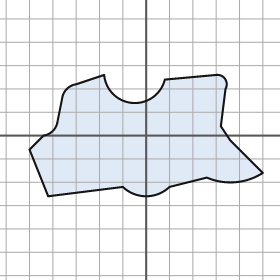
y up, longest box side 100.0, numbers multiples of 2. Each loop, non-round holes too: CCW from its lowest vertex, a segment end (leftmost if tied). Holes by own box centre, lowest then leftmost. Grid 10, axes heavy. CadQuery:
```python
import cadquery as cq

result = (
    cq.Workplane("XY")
    .moveTo(-42.0, -26.0)
    .lineTo(-10.0, -22.0)
    .threePointArc((0.0, -26.0), (10.0, -22.0))
    .lineTo(26.0, -18.0)
    .threePointArc((38.0, -20.0), (50.0, -16.0))
    .lineTo(36.0, -2.0)
    .lineTo(32.0, 4.0)
    .lineTo(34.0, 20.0)
    .threePointArc((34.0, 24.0), (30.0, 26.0))
    .lineTo(8.0, 24.0)
    .threePointArc((-6.0, 14.0), (-18.0, 26.0))
    .lineTo(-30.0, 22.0)
    .threePointArc((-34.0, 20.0), (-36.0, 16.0))
    .lineTo(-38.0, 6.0)
    .threePointArc((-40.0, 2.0), (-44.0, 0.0))
    .lineTo(-50.0, -6.0)
    .close()
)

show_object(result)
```